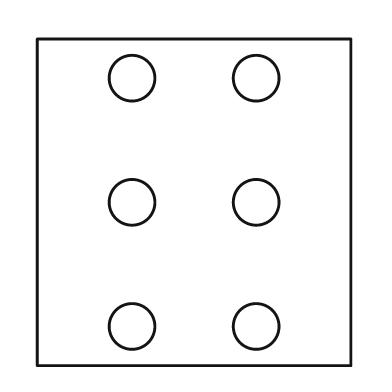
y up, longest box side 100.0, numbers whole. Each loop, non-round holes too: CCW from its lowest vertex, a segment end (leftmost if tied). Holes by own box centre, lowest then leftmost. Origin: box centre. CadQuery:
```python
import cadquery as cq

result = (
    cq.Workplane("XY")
    .moveTo(-48.0, -50.0)
    .lineTo(48.0, -50.0)
    .lineTo(48.0, 50.0)
    .lineTo(-48.0, 50.0)
    .close()
    .moveTo(-19.0, -38.0)
    .circle(7.0)
    .moveTo(19.0, -38.0)
    .circle(7.0)
    .moveTo(-19.0, 0.0)
    .circle(7.0)
    .moveTo(19.0, 0.0)
    .circle(7.0)
    .moveTo(-19.0, 38.0)
    .circle(7.0)
    .moveTo(19.0, 38.0)
    .circle(7.0)
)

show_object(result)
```